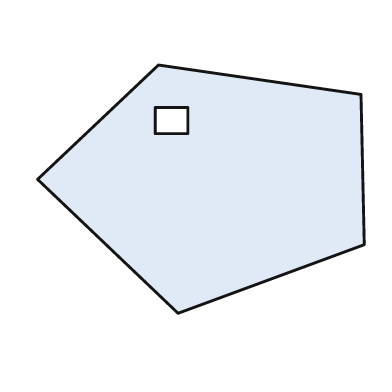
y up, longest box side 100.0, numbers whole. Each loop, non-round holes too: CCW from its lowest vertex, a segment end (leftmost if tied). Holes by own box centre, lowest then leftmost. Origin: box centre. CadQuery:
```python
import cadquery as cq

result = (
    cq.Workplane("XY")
    .moveTo(-7.0, -38.0)
    .lineTo(50.0, -17.0)
    .lineTo(49.0, 29.0)
    .lineTo(-13.0, 38.0)
    .lineTo(-50.0, 3.0)
    .close()
    .moveTo(-14.0, 17.0)
    .lineTo(-4.0, 17.0)
    .lineTo(-4.0, 25.0)
    .lineTo(-14.0, 25.0)
    .close()
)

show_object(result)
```